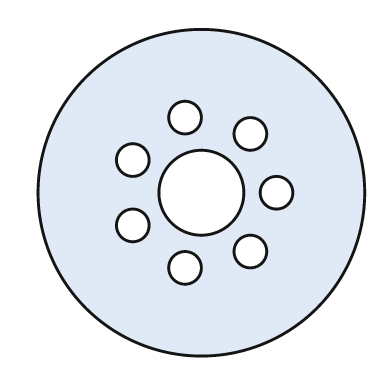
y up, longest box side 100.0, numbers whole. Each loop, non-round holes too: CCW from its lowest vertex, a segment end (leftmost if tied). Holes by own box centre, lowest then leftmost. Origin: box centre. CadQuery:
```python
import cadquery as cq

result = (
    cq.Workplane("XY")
    .moveTo(0.0, 0.0)
    .circle(50.0)
    .moveTo(-5.0, -23.0)
    .circle(5.0)
    .moveTo(15.0, -18.0)
    .circle(5.0)
    .moveTo(-21.0, -10.0)
    .circle(5.0)
    .moveTo(0.0, 0.0)
    .circle(13.0)
    .moveTo(23.0, 0.0)
    .circle(5.0)
    .moveTo(-21.0, 10.0)
    .circle(5.0)
    .moveTo(15.0, 18.0)
    .circle(5.0)
    .moveTo(-5.0, 23.0)
    .circle(5.0)
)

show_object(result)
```